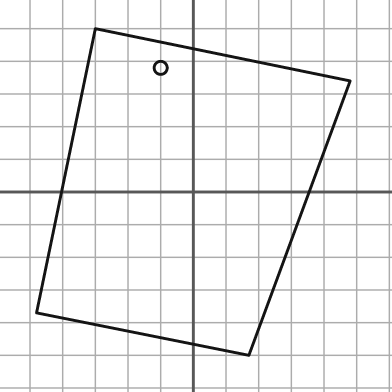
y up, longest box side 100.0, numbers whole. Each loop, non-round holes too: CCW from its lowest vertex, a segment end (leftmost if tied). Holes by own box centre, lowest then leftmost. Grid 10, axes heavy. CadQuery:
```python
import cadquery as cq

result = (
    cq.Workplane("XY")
    .moveTo(17.0, -50.0)
    .lineTo(48.0, 34.0)
    .lineTo(-30.0, 50.0)
    .lineTo(-48.0, -37.0)
    .close()
    .moveTo(-10.0, 38.0)
    .circle(2.0)
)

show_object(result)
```